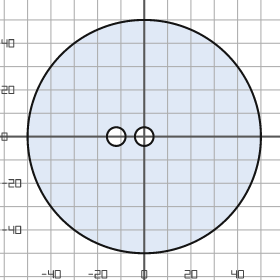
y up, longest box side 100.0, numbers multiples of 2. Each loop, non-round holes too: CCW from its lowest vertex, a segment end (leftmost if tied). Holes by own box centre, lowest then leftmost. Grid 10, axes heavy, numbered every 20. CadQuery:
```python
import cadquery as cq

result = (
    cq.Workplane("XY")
    .moveTo(0.0, 0.0)
    .circle(50.0)
    .moveTo(-12.0, 0.0)
    .circle(4.0)
    .moveTo(0.0, 0.0)
    .circle(4.0)
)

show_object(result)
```